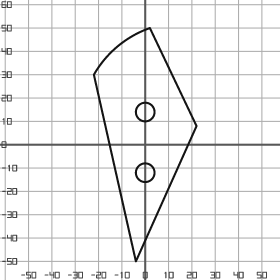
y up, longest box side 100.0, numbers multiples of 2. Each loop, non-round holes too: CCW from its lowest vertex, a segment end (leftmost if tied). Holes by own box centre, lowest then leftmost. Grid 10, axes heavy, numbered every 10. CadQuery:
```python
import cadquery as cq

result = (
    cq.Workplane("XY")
    .moveTo(-4.0, -50.0)
    .lineTo(22.0, 8.0)
    .lineTo(2.0, 50.0)
    .threePointArc((-12.0, 42.0), (-22.0, 30.0))
    .close()
    .moveTo(0.0, -12.0)
    .circle(4.0)
    .moveTo(0.0, 14.0)
    .circle(4.0)
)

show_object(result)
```